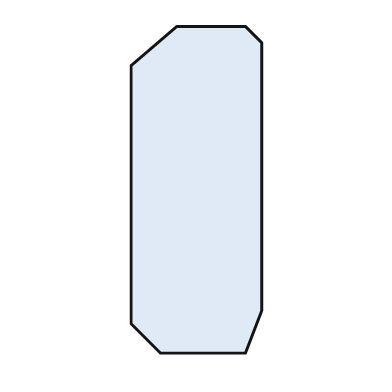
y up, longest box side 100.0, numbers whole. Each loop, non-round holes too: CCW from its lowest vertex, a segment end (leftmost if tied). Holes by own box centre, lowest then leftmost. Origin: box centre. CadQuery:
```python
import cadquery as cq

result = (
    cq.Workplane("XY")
    .moveTo(-11.0, -50.0)
    .lineTo(15.0, -50.0)
    .lineTo(20.0, -37.0)
    .lineTo(20.0, 45.0)
    .lineTo(15.0, 50.0)
    .lineTo(-6.0, 50.0)
    .lineTo(-20.0, 38.0)
    .lineTo(-20.0, -41.0)
    .close()
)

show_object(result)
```